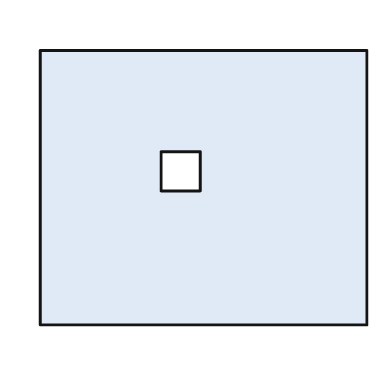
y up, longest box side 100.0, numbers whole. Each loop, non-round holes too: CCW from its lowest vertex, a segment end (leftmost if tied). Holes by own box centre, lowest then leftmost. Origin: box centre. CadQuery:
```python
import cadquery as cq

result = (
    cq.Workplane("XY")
    .moveTo(-50.0, -42.0)
    .lineTo(50.0, -42.0)
    .lineTo(50.0, 42.0)
    .lineTo(-50.0, 42.0)
    .close()
    .moveTo(-13.0, -1.0)
    .lineTo(-1.0, -1.0)
    .lineTo(-1.0, 11.0)
    .lineTo(-13.0, 11.0)
    .close()
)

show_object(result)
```